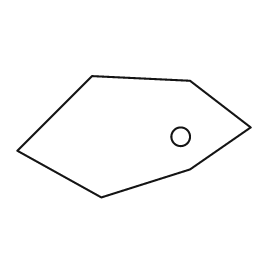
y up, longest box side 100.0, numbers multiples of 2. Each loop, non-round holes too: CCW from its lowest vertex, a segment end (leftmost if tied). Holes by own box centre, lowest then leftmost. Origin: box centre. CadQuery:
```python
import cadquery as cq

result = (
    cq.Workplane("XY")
    .moveTo(-14.0, -26.0)
    .lineTo(24.0, -14.0)
    .lineTo(50.0, 4.0)
    .lineTo(24.0, 24.0)
    .lineTo(-18.0, 26.0)
    .lineTo(-50.0, -6.0)
    .close()
    .moveTo(20.0, 0.0)
    .circle(4.0)
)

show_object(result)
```